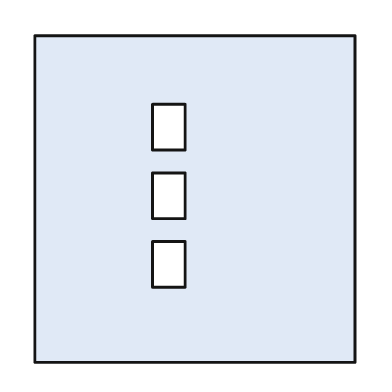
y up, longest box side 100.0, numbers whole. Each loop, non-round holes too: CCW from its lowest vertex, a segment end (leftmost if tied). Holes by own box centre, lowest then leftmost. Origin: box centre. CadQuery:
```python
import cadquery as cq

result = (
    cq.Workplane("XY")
    .moveTo(-49.0, -50.0)
    .lineTo(49.0, -50.0)
    .lineTo(49.0, 50.0)
    .lineTo(-49.0, 50.0)
    .close()
    .moveTo(-13.0, -27.0)
    .lineTo(-3.0, -27.0)
    .lineTo(-3.0, -13.0)
    .lineTo(-13.0, -13.0)
    .close()
    .moveTo(-13.0, -6.0)
    .lineTo(-3.0, -6.0)
    .lineTo(-3.0, 8.0)
    .lineTo(-13.0, 8.0)
    .close()
    .moveTo(-13.0, 15.0)
    .lineTo(-3.0, 15.0)
    .lineTo(-3.0, 29.0)
    .lineTo(-13.0, 29.0)
    .close()
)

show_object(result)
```